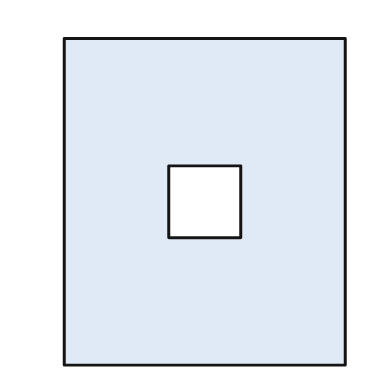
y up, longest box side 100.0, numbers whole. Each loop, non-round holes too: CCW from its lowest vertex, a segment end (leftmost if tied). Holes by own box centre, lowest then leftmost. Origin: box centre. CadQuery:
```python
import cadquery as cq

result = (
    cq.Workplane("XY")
    .moveTo(-43.0, -50.0)
    .lineTo(43.0, -50.0)
    .lineTo(43.0, 50.0)
    .lineTo(-43.0, 50.0)
    .close()
    .moveTo(-11.0, -11.0)
    .lineTo(11.0, -11.0)
    .lineTo(11.0, 11.0)
    .lineTo(-11.0, 11.0)
    .close()
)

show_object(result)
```